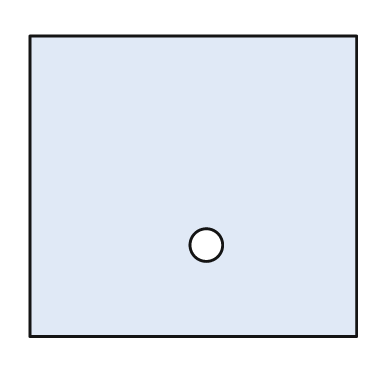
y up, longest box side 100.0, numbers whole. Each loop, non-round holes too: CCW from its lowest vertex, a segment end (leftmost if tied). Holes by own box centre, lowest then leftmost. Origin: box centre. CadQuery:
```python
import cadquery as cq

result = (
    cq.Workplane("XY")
    .moveTo(-50.0, -46.0)
    .lineTo(50.0, -46.0)
    .lineTo(50.0, 46.0)
    .lineTo(-50.0, 46.0)
    .close()
    .moveTo(4.0, -18.0)
    .circle(5.0)
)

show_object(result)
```